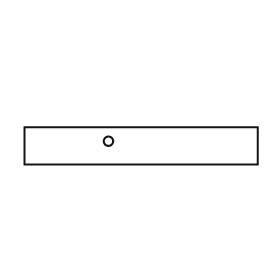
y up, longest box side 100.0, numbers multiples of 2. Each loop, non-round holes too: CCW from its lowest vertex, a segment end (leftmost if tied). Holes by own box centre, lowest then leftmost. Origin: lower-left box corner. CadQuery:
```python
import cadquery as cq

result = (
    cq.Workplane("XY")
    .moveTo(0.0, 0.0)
    .lineTo(100.0, 0.0)
    .lineTo(100.0, 16.0)
    .lineTo(0.0, 16.0)
    .close()
    .moveTo(36.0, 10.0)
    .circle(2.0)
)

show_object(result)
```